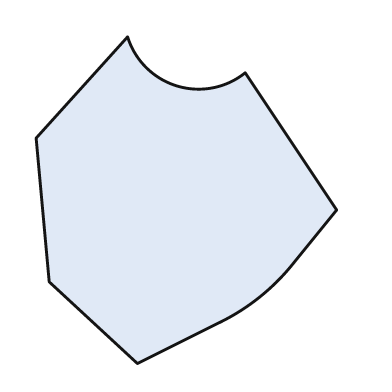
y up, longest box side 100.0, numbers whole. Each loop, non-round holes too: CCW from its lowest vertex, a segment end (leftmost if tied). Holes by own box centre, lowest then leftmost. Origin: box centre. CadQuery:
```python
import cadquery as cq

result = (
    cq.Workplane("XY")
    .moveTo(-15.0, -50.0)
    .lineTo(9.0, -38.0)
    .threePointArc((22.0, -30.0), (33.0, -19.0))
    .lineTo(46.0, -3.0)
    .lineTo(18.0, 39.0)
    .threePointArc((-3.0, 35.0), (-18.0, 50.0))
    .lineTo(-46.0, 19.0)
    .lineTo(-42.0, -25.0)
    .close()
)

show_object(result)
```